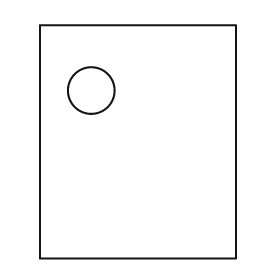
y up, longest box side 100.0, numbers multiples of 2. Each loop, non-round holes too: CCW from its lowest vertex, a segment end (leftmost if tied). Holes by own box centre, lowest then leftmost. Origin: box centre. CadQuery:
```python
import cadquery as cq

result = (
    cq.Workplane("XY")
    .moveTo(-42.0, -50.0)
    .lineTo(42.0, -50.0)
    .lineTo(42.0, 50.0)
    .lineTo(-42.0, 50.0)
    .close()
    .moveTo(-20.0, 22.0)
    .circle(10.0)
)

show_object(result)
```